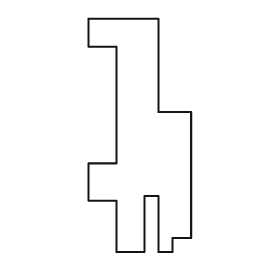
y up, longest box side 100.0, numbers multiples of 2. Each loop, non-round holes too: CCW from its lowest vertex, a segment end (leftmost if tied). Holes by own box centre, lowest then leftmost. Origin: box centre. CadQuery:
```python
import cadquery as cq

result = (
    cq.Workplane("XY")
    .moveTo(-10.0, -50.0)
    .lineTo(2.0, -50.0)
    .lineTo(2.0, -26.0)
    .lineTo(8.0, -26.0)
    .lineTo(8.0, -50.0)
    .lineTo(14.0, -50.0)
    .lineTo(14.0, -44.0)
    .lineTo(22.0, -44.0)
    .lineTo(22.0, 10.0)
    .lineTo(8.0, 10.0)
    .lineTo(8.0, 50.0)
    .lineTo(-22.0, 50.0)
    .lineTo(-22.0, 38.0)
    .lineTo(-10.0, 38.0)
    .lineTo(-10.0, -12.0)
    .lineTo(-22.0, -12.0)
    .lineTo(-22.0, -28.0)
    .lineTo(-10.0, -28.0)
    .close()
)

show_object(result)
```